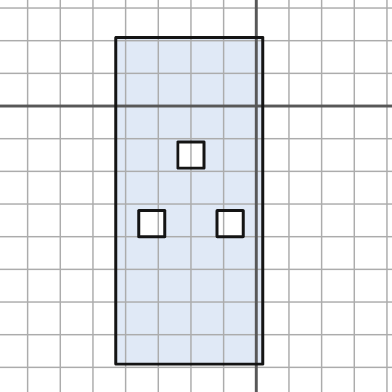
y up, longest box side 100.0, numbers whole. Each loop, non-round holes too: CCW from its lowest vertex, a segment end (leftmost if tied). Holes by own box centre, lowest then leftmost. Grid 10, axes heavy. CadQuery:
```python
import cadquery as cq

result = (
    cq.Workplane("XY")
    .moveTo(-43.0, -79.0)
    .lineTo(2.0, -79.0)
    .lineTo(2.0, 21.0)
    .lineTo(-43.0, 21.0)
    .close()
    .moveTo(-36.0, -40.0)
    .lineTo(-28.0, -40.0)
    .lineTo(-28.0, -32.0)
    .lineTo(-36.0, -32.0)
    .close()
    .moveTo(-12.0, -40.0)
    .lineTo(-4.0, -40.0)
    .lineTo(-4.0, -32.0)
    .lineTo(-12.0, -32.0)
    .close()
    .moveTo(-24.0, -19.0)
    .lineTo(-16.0, -19.0)
    .lineTo(-16.0, -11.0)
    .lineTo(-24.0, -11.0)
    .close()
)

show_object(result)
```